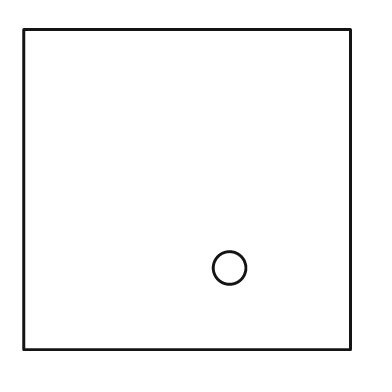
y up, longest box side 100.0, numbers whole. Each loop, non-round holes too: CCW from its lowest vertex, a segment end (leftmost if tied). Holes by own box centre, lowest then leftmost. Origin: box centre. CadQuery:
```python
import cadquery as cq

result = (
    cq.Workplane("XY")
    .moveTo(-50.0, -49.0)
    .lineTo(50.0, -49.0)
    .lineTo(50.0, 49.0)
    .lineTo(-50.0, 49.0)
    .close()
    .moveTo(13.0, -24.0)
    .circle(5.0)
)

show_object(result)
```